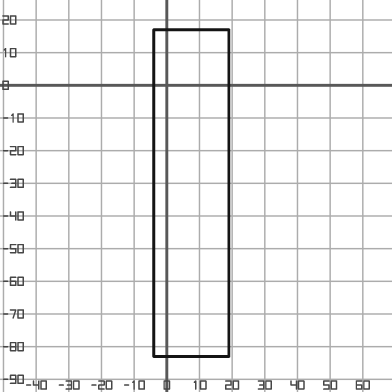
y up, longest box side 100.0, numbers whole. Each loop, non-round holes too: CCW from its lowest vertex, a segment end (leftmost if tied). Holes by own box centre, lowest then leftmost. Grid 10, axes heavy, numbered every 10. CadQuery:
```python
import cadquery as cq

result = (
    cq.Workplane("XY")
    .moveTo(-4.0, -83.0)
    .lineTo(19.0, -83.0)
    .lineTo(19.0, 17.0)
    .lineTo(-4.0, 17.0)
    .close()
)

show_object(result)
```